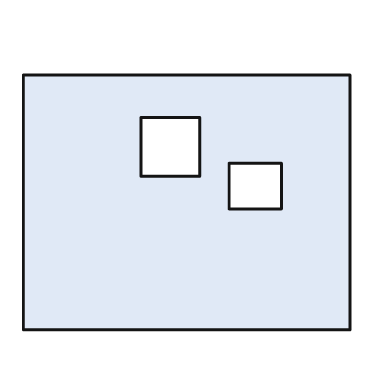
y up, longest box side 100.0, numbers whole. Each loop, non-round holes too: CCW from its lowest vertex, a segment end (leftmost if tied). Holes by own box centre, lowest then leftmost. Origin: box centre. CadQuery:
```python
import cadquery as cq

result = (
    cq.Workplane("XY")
    .moveTo(-50.0, -39.0)
    .lineTo(50.0, -39.0)
    .lineTo(50.0, 39.0)
    .lineTo(-50.0, 39.0)
    .close()
    .moveTo(13.0, -2.0)
    .lineTo(29.0, -2.0)
    .lineTo(29.0, 12.0)
    .lineTo(13.0, 12.0)
    .close()
    .moveTo(-14.0, 8.0)
    .lineTo(4.0, 8.0)
    .lineTo(4.0, 26.0)
    .lineTo(-14.0, 26.0)
    .close()
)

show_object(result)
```